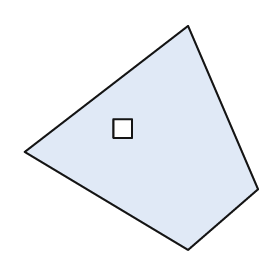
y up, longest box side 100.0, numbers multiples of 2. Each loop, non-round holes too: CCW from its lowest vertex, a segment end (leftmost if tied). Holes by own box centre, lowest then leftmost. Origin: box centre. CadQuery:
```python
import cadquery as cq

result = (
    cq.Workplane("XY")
    .moveTo(20.0, -48.0)
    .lineTo(50.0, -22.0)
    .lineTo(20.0, 48.0)
    .lineTo(-50.0, -6.0)
    .close()
    .moveTo(-12.0, 0.0)
    .lineTo(-4.0, 0.0)
    .lineTo(-4.0, 8.0)
    .lineTo(-12.0, 8.0)
    .close()
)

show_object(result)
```